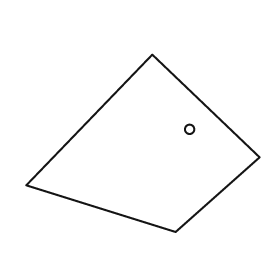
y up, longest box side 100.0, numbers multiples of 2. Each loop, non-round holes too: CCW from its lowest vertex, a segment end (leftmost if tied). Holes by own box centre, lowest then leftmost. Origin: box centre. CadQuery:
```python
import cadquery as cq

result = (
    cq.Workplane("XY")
    .moveTo(14.0, -38.0)
    .lineTo(50.0, -6.0)
    .lineTo(4.0, 38.0)
    .lineTo(-50.0, -18.0)
    .close()
    .moveTo(20.0, 6.0)
    .circle(2.0)
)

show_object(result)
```